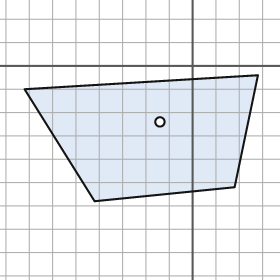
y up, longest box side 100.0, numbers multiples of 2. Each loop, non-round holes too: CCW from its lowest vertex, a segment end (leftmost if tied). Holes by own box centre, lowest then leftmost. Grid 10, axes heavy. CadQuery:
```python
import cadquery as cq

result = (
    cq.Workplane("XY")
    .moveTo(-42.0, -58.0)
    .lineTo(18.0, -52.0)
    .lineTo(28.0, -4.0)
    .lineTo(-72.0, -10.0)
    .close()
    .moveTo(-14.0, -24.0)
    .circle(2.0)
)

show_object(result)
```